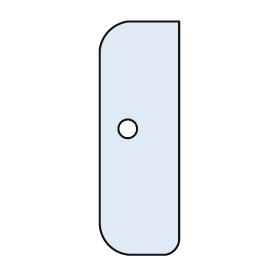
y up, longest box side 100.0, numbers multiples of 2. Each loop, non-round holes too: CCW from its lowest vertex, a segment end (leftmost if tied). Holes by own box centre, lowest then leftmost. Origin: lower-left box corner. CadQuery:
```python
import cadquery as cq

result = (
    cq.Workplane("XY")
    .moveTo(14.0, 0.0)
    .lineTo(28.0, 0.0)
    .threePointArc((32.0, 2.0), (34.0, 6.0))
    .lineTo(34.0, 100.0)
    .lineTo(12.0, 100.0)
    .threePointArc((4.0, 96.0), (0.0, 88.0))
    .lineTo(0.0, 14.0)
    .threePointArc((4.0, 4.0), (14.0, 0.0))
    .close()
    .moveTo(12.0, 54.0)
    .circle(4.0)
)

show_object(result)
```